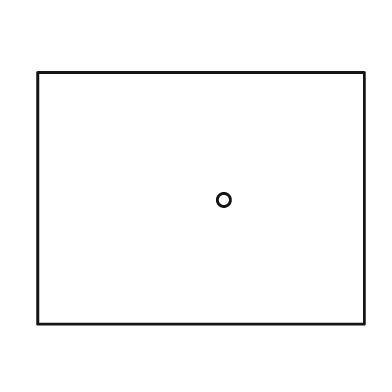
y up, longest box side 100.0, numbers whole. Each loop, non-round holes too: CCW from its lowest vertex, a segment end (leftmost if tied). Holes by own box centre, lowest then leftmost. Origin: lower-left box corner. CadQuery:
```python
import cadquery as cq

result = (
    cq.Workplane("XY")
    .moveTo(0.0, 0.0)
    .lineTo(100.0, 0.0)
    .lineTo(100.0, 77.0)
    .lineTo(0.0, 77.0)
    .close()
    .moveTo(57.0, 38.0)
    .circle(2.0)
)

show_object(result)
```